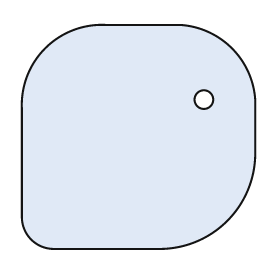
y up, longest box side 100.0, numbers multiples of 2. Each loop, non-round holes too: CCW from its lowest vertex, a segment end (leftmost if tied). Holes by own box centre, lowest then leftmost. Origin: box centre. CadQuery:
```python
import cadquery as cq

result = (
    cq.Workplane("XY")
    .moveTo(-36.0, -48.0)
    .lineTo(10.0, -48.0)
    .threePointArc((38.0, -36.0), (50.0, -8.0))
    .lineTo(50.0, 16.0)
    .threePointArc((40.0, 38.0), (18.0, 48.0))
    .lineTo(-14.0, 48.0)
    .threePointArc((-40.0, 38.0), (-50.0, 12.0))
    .lineTo(-50.0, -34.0)
    .threePointArc((-46.0, -44.0), (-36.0, -48.0))
    .close()
    .moveTo(28.0, 16.0)
    .circle(4.0)
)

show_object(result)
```